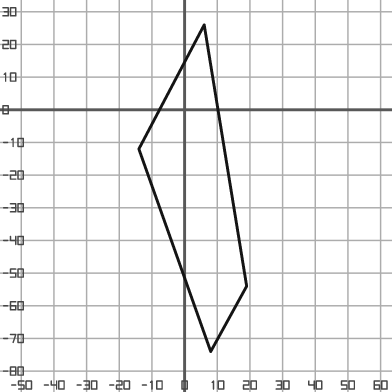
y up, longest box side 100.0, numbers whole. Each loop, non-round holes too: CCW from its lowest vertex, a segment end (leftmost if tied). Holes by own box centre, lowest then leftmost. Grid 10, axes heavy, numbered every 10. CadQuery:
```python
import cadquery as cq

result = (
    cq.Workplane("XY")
    .moveTo(8.0, -74.0)
    .lineTo(19.0, -54.0)
    .lineTo(6.0, 26.0)
    .lineTo(-14.0, -12.0)
    .close()
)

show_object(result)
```